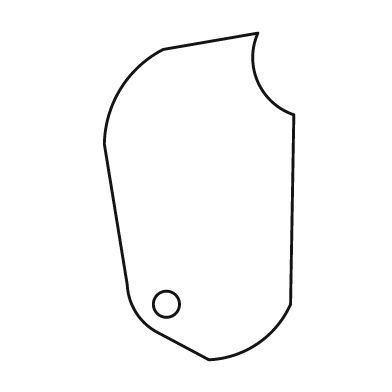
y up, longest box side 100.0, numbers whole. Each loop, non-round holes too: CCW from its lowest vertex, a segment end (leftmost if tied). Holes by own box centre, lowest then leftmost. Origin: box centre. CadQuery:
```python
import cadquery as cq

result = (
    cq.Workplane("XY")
    .moveTo(3.0, -50.0)
    .threePointArc((18.0, -45.0), (28.0, -33.0))
    .lineTo(29.0, 25.0)
    .threePointArc((18.0, 35.0), (18.0, 50.0))
    .lineTo(-11.0, 45.0)
    .threePointArc((-24.0, 33.0), (-29.0, 16.0))
    .lineTo(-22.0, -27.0)
    .threePointArc((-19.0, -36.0), (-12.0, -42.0))
    .close()
    .moveTo(-10.0, -33.0)
    .circle(4.0)
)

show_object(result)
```